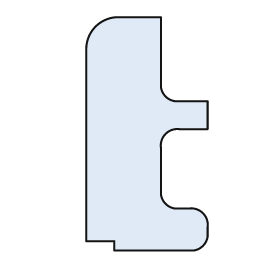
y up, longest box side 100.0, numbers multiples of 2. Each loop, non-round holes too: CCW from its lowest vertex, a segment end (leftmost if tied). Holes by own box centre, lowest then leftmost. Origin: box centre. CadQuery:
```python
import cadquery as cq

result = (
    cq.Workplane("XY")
    .moveTo(-14.0, -50.0)
    .lineTo(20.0, -50.0)
    .threePointArc((24.0, -48.0), (26.0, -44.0))
    .lineTo(26.0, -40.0)
    .threePointArc((24.0, -34.0), (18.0, -32.0))
    .lineTo(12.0, -32.0)
    .threePointArc((8.0, -30.0), (6.0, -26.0))
    .lineTo(6.0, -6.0)
    .threePointArc((8.0, 0.0), (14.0, 2.0))
    .lineTo(26.0, 2.0)
    .lineTo(26.0, 14.0)
    .lineTo(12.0, 14.0)
    .threePointArc((8.0, 16.0), (6.0, 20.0))
    .lineTo(6.0, 50.0)
    .lineTo(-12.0, 50.0)
    .threePointArc((-22.0, 46.0), (-26.0, 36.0))
    .lineTo(-26.0, -46.0)
    .lineTo(-14.0, -46.0)
    .close()
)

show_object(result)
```